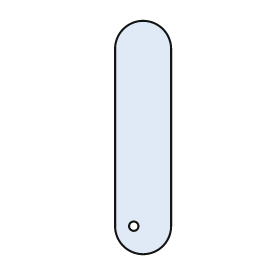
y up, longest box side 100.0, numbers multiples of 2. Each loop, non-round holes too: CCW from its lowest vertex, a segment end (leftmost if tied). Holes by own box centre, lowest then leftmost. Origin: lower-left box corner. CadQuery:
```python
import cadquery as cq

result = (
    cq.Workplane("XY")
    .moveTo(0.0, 12.0)
    .threePointArc((12.0, 0.0), (24.0, 12.0))
    .lineTo(24.0, 88.0)
    .threePointArc((12.0, 100.0), (0.0, 88.0))
    .close()
    .moveTo(8.0, 12.0)
    .circle(2.0)
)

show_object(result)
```